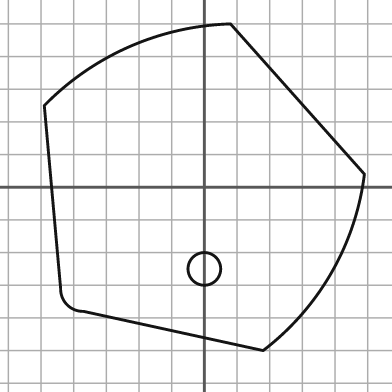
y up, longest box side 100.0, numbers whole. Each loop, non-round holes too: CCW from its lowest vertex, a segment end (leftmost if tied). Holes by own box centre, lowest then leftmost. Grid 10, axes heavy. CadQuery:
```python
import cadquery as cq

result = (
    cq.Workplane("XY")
    .moveTo(18.0, -50.0)
    .threePointArc((39.0, -26.0), (49.0, 4.0))
    .lineTo(8.0, 50.0)
    .threePointArc((-23.0, 43.0), (-49.0, 25.0))
    .lineTo(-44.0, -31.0)
    .threePointArc((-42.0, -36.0), (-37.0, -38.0))
    .close()
    .moveTo(0.0, -25.0)
    .circle(5.0)
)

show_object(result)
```